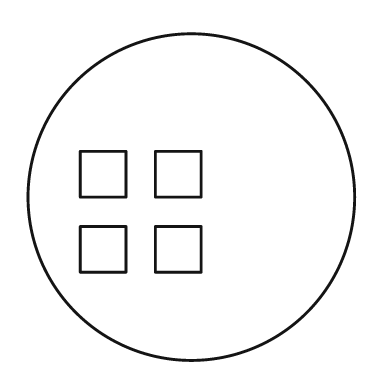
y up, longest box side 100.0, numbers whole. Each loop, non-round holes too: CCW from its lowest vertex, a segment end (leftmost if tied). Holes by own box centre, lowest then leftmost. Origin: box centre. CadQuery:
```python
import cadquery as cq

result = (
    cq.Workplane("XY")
    .moveTo(0.0, 0.0)
    .circle(50.0)
    .moveTo(-34.0, -23.0)
    .lineTo(-20.0, -23.0)
    .lineTo(-20.0, -9.0)
    .lineTo(-34.0, -9.0)
    .close()
    .moveTo(-11.0, -23.0)
    .lineTo(3.0, -23.0)
    .lineTo(3.0, -9.0)
    .lineTo(-11.0, -9.0)
    .close()
    .moveTo(-34.0, 0.0)
    .lineTo(-20.0, 0.0)
    .lineTo(-20.0, 14.0)
    .lineTo(-34.0, 14.0)
    .close()
    .moveTo(-11.0, 0.0)
    .lineTo(3.0, 0.0)
    .lineTo(3.0, 14.0)
    .lineTo(-11.0, 14.0)
    .close()
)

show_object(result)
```